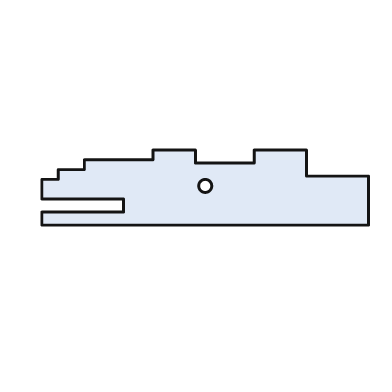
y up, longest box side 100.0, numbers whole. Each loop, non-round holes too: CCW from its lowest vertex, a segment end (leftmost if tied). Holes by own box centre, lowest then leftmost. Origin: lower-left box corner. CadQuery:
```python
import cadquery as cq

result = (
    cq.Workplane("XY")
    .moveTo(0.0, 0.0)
    .lineTo(100.0, 0.0)
    .lineTo(100.0, 15.0)
    .lineTo(81.0, 15.0)
    .lineTo(81.0, 23.0)
    .lineTo(65.0, 23.0)
    .lineTo(65.0, 19.0)
    .lineTo(47.0, 19.0)
    .lineTo(47.0, 23.0)
    .lineTo(34.0, 23.0)
    .lineTo(34.0, 20.0)
    .lineTo(13.0, 20.0)
    .lineTo(13.0, 17.0)
    .lineTo(5.0, 17.0)
    .lineTo(5.0, 14.0)
    .lineTo(0.0, 14.0)
    .lineTo(0.0, 8.0)
    .lineTo(25.0, 8.0)
    .lineTo(25.0, 4.0)
    .lineTo(0.0, 4.0)
    .close()
    .moveTo(50.0, 12.0)
    .circle(2.0)
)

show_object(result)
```